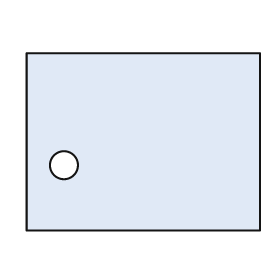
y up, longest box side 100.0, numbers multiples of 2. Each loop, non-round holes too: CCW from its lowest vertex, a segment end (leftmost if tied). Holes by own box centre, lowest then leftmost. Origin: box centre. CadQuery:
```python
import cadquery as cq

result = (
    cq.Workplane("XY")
    .moveTo(-50.0, -38.0)
    .lineTo(50.0, -38.0)
    .lineTo(50.0, 38.0)
    .lineTo(-50.0, 38.0)
    .close()
    .moveTo(-34.0, -10.0)
    .circle(6.0)
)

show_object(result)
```